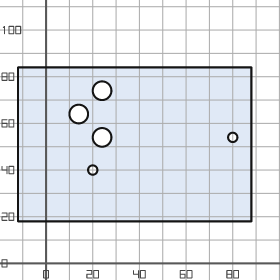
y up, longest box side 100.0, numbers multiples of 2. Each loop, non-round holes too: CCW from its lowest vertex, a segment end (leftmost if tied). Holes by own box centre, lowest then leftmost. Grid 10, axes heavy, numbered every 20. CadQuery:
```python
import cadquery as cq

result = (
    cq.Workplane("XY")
    .moveTo(-12.0, 18.0)
    .lineTo(88.0, 18.0)
    .lineTo(88.0, 84.0)
    .lineTo(-12.0, 84.0)
    .close()
    .moveTo(20.0, 40.0)
    .circle(2.0)
    .moveTo(24.0, 54.0)
    .circle(4.0)
    .moveTo(80.0, 54.0)
    .circle(2.0)
    .moveTo(14.0, 64.0)
    .circle(4.0)
    .moveTo(24.0, 74.0)
    .circle(4.0)
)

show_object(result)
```